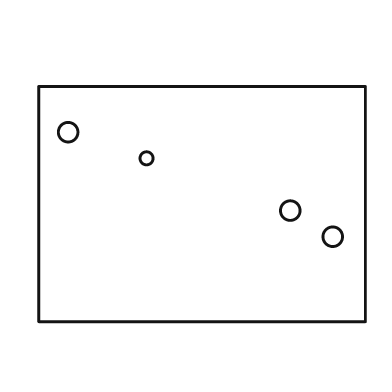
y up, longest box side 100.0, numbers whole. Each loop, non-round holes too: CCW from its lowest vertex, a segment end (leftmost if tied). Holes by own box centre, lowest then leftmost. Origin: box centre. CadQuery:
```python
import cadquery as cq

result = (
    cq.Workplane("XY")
    .moveTo(-50.0, -36.0)
    .lineTo(50.0, -36.0)
    .lineTo(50.0, 36.0)
    .lineTo(-50.0, 36.0)
    .close()
    .moveTo(40.0, -10.0)
    .circle(3.0)
    .moveTo(27.0, -2.0)
    .circle(3.0)
    .moveTo(-17.0, 14.0)
    .circle(2.0)
    .moveTo(-41.0, 22.0)
    .circle(3.0)
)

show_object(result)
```